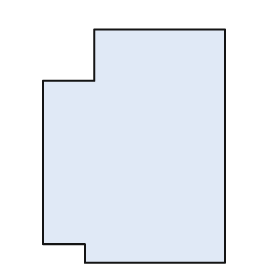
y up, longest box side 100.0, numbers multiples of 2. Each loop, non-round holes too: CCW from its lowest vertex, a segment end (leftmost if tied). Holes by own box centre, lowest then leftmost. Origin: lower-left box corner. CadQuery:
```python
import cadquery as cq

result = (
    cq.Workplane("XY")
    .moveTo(18.0, 0.0)
    .lineTo(78.0, 0.0)
    .lineTo(78.0, 100.0)
    .lineTo(22.0, 100.0)
    .lineTo(22.0, 78.0)
    .lineTo(0.0, 78.0)
    .lineTo(0.0, 8.0)
    .lineTo(18.0, 8.0)
    .close()
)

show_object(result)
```